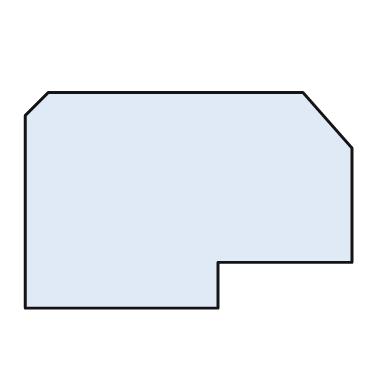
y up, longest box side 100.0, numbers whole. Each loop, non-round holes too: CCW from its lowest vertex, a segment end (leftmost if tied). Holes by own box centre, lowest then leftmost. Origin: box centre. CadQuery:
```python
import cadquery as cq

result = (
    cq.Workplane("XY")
    .moveTo(-50.0, -33.0)
    .lineTo(9.0, -33.0)
    .lineTo(9.0, -19.0)
    .lineTo(50.0, -19.0)
    .lineTo(50.0, 16.0)
    .lineTo(35.0, 33.0)
    .lineTo(-43.0, 33.0)
    .lineTo(-50.0, 26.0)
    .close()
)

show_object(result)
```